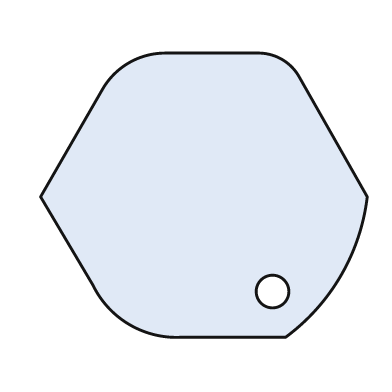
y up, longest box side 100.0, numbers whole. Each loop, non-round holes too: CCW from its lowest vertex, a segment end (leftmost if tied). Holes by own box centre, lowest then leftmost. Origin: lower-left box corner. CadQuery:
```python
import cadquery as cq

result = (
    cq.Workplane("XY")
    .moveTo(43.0, 0.0)
    .lineTo(75.0, 0.0)
    .threePointArc((92.0, 19.0), (100.0, 43.0))
    .lineTo(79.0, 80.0)
    .threePointArc((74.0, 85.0), (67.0, 87.0))
    .lineTo(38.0, 87.0)
    .threePointArc((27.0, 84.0), (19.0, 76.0))
    .lineTo(0.0, 43.0)
    .lineTo(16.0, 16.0)
    .threePointArc((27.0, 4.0), (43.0, 0.0))
    .close()
    .moveTo(71.0, 14.0)
    .circle(5.0)
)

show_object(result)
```